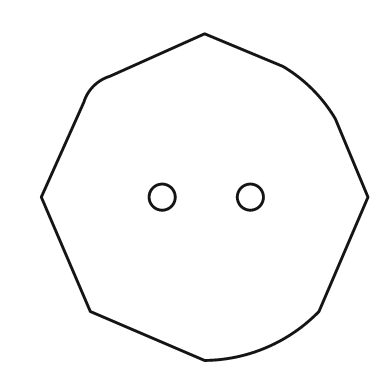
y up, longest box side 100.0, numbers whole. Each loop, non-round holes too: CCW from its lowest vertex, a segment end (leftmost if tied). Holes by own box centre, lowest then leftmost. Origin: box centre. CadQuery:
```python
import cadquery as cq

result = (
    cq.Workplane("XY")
    .moveTo(0.0, -50.0)
    .threePointArc((19.0, -46.0), (35.0, -35.0))
    .lineTo(50.0, 0.0)
    .lineTo(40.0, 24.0)
    .threePointArc((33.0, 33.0), (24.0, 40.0))
    .lineTo(0.0, 50.0)
    .lineTo(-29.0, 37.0)
    .threePointArc((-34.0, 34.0), (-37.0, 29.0))
    .lineTo(-50.0, 0.0)
    .lineTo(-35.0, -35.0)
    .close()
    .moveTo(-13.0, 0.0)
    .circle(4.0)
    .moveTo(14.0, 0.0)
    .circle(4.0)
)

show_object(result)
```